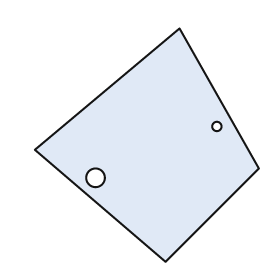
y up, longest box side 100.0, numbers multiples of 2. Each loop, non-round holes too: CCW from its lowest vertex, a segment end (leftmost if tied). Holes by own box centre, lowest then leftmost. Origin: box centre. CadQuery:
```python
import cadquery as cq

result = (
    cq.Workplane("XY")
    .moveTo(8.0, -50.0)
    .lineTo(48.0, -10.0)
    .lineTo(14.0, 50.0)
    .lineTo(-48.0, -2.0)
    .close()
    .moveTo(-22.0, -14.0)
    .circle(4.0)
    .moveTo(30.0, 8.0)
    .circle(2.0)
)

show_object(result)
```